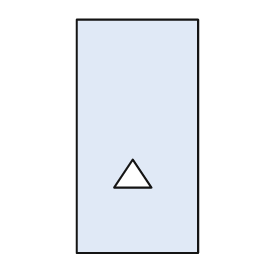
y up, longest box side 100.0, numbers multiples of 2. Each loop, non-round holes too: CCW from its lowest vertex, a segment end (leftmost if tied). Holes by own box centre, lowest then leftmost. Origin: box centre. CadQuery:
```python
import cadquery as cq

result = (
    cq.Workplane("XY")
    .moveTo(-26.0, -50.0)
    .lineTo(26.0, -50.0)
    .lineTo(26.0, 50.0)
    .lineTo(-26.0, 50.0)
    .close()
    .moveTo(-10.0, -22.0)
    .lineTo(6.0, -22.0)
    .lineTo(-2.0, -10.0)
    .close()
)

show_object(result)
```